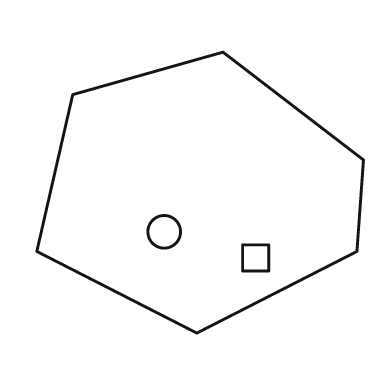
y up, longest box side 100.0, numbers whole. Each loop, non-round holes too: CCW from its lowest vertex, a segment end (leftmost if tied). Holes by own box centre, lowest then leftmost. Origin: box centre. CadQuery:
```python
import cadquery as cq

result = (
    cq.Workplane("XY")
    .moveTo(-1.0, -43.0)
    .lineTo(48.0, -18.0)
    .lineTo(50.0, 10.0)
    .lineTo(7.0, 43.0)
    .lineTo(-39.0, 30.0)
    .lineTo(-50.0, -18.0)
    .close()
    .moveTo(13.0, -24.0)
    .lineTo(21.0, -24.0)
    .lineTo(21.0, -16.0)
    .lineTo(13.0, -16.0)
    .close()
    .moveTo(-11.0, -12.0)
    .circle(5.0)
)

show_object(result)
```